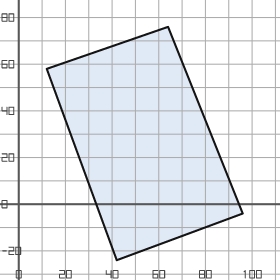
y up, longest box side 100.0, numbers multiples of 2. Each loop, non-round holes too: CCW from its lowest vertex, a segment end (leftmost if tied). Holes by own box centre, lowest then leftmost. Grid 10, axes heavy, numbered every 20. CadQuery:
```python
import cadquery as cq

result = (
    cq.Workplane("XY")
    .moveTo(42.0, -24.0)
    .lineTo(96.0, -4.0)
    .lineTo(64.0, 76.0)
    .lineTo(12.0, 58.0)
    .close()
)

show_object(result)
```